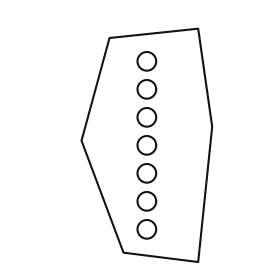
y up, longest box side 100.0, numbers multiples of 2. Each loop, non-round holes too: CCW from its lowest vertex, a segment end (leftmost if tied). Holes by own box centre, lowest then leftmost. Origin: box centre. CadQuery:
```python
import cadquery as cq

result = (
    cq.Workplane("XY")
    .moveTo(22.0, -50.0)
    .lineTo(28.0, 8.0)
    .lineTo(22.0, 50.0)
    .lineTo(-16.0, 46.0)
    .lineTo(-28.0, 2.0)
    .lineTo(-10.0, -46.0)
    .close()
    .moveTo(0.0, -36.0)
    .circle(4.0)
    .moveTo(0.0, -24.0)
    .circle(4.0)
    .moveTo(0.0, -12.0)
    .circle(4.0)
    .moveTo(0.0, 0.0)
    .circle(4.0)
    .moveTo(0.0, 12.0)
    .circle(4.0)
    .moveTo(0.0, 24.0)
    .circle(4.0)
    .moveTo(0.0, 36.0)
    .circle(4.0)
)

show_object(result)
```